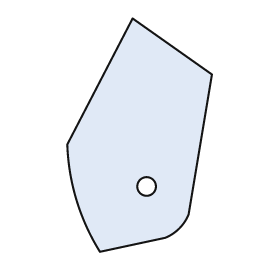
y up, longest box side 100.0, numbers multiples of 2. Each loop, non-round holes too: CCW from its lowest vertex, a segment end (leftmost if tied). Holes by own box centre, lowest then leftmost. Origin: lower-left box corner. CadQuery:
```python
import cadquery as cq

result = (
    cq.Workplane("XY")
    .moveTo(14.0, 0.0)
    .lineTo(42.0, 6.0)
    .threePointArc((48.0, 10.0), (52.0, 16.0))
    .lineTo(62.0, 76.0)
    .lineTo(28.0, 100.0)
    .lineTo(0.0, 46.0)
    .threePointArc((4.0, 22.0), (14.0, 0.0))
    .close()
    .moveTo(34.0, 28.0)
    .circle(4.0)
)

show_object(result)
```